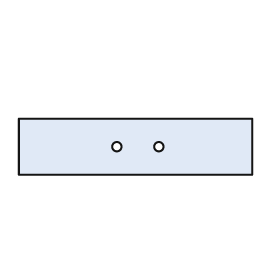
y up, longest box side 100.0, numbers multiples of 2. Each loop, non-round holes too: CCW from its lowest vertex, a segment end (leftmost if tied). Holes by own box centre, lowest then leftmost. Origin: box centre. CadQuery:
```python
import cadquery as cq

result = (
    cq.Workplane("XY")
    .moveTo(-50.0, -12.0)
    .lineTo(50.0, -12.0)
    .lineTo(50.0, 12.0)
    .lineTo(-50.0, 12.0)
    .close()
    .moveTo(-8.0, 0.0)
    .circle(2.0)
    .moveTo(10.0, 0.0)
    .circle(2.0)
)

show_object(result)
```